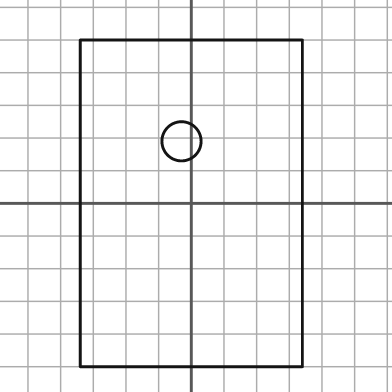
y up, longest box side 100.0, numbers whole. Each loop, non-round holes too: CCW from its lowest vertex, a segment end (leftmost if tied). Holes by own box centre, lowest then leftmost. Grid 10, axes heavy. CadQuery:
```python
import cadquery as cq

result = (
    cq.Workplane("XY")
    .moveTo(-34.0, -50.0)
    .lineTo(34.0, -50.0)
    .lineTo(34.0, 50.0)
    .lineTo(-34.0, 50.0)
    .close()
    .moveTo(-3.0, 19.0)
    .circle(6.0)
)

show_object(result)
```